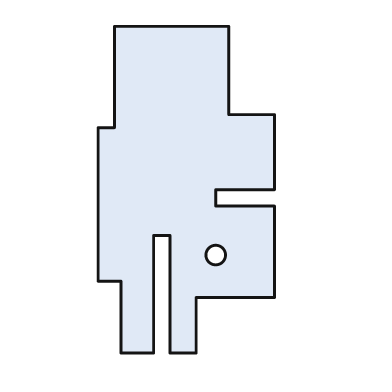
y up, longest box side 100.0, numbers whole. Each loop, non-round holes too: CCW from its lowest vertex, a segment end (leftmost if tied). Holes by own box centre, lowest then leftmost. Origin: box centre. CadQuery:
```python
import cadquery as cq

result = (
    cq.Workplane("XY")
    .moveTo(-20.0, -50.0)
    .lineTo(-10.0, -50.0)
    .lineTo(-10.0, -14.0)
    .lineTo(-5.0, -14.0)
    .lineTo(-5.0, -50.0)
    .lineTo(3.0, -50.0)
    .lineTo(3.0, -33.0)
    .lineTo(27.0, -33.0)
    .lineTo(27.0, -5.0)
    .lineTo(9.0, -5.0)
    .lineTo(9.0, 0.0)
    .lineTo(27.0, 0.0)
    .lineTo(27.0, 23.0)
    .lineTo(13.0, 23.0)
    .lineTo(13.0, 50.0)
    .lineTo(-22.0, 50.0)
    .lineTo(-22.0, 19.0)
    .lineTo(-27.0, 19.0)
    .lineTo(-27.0, -28.0)
    .lineTo(-20.0, -28.0)
    .close()
    .moveTo(9.0, -20.0)
    .circle(3.0)
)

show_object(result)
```